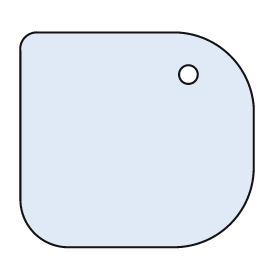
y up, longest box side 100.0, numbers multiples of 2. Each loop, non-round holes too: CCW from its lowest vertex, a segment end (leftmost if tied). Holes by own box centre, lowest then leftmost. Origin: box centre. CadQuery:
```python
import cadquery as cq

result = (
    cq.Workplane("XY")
    .moveTo(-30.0, -46.0)
    .lineTo(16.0, -46.0)
    .threePointArc((40.0, -36.0), (50.0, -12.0))
    .lineTo(50.0, 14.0)
    .threePointArc((40.0, 36.0), (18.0, 46.0))
    .lineTo(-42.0, 46.0)
    .threePointArc((-48.0, 44.0), (-50.0, 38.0))
    .lineTo(-50.0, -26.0)
    .threePointArc((-44.0, -40.0), (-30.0, -46.0))
    .close()
    .moveTo(22.0, 28.0)
    .circle(4.0)
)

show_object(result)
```